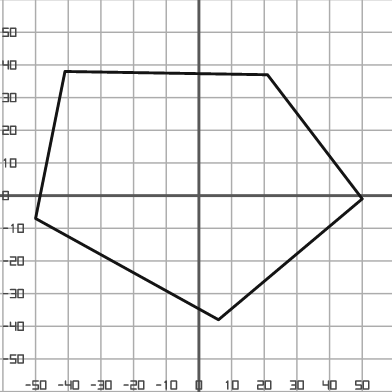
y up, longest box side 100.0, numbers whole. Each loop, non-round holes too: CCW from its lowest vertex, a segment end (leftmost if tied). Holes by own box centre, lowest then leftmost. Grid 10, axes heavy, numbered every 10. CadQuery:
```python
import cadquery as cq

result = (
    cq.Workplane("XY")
    .moveTo(6.0, -38.0)
    .lineTo(50.0, -1.0)
    .lineTo(21.0, 37.0)
    .lineTo(-41.0, 38.0)
    .lineTo(-50.0, -7.0)
    .close()
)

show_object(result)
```